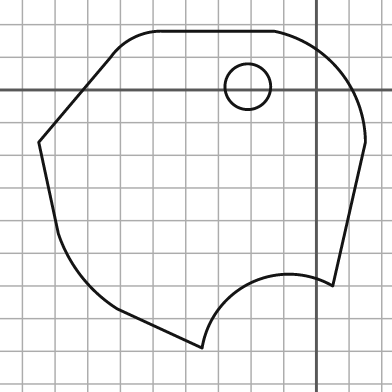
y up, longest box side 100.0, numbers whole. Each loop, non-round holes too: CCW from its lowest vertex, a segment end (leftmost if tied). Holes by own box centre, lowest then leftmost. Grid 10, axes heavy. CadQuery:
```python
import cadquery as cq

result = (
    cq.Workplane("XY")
    .moveTo(-35.0, -79.0)
    .threePointArc((-20.0, -59.0), (5.0, -60.0))
    .lineTo(15.0, -16.0)
    .threePointArc((7.0, 6.0), (-13.0, 18.0))
    .lineTo(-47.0, 18.0)
    .threePointArc((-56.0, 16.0), (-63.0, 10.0))
    .lineTo(-85.0, -16.0)
    .lineTo(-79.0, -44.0)
    .threePointArc((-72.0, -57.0), (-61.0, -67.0))
    .close()
    .moveTo(-21.0, 1.0)
    .circle(7.0)
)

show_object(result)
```